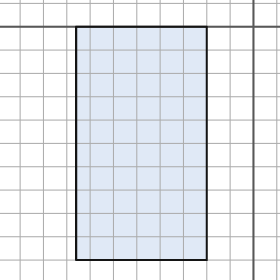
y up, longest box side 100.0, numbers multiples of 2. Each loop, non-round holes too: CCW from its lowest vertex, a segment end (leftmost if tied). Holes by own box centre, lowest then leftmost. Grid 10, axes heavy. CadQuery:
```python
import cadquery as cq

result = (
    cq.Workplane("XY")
    .moveTo(-76.0, -100.0)
    .lineTo(-20.0, -100.0)
    .lineTo(-20.0, 0.0)
    .lineTo(-76.0, 0.0)
    .close()
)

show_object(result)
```